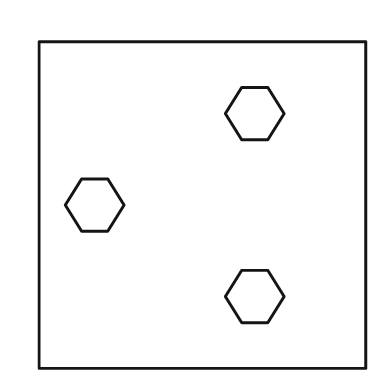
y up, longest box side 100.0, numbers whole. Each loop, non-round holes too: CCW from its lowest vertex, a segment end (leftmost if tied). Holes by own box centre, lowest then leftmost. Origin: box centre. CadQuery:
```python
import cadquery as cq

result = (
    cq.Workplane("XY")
    .moveTo(-50.0, -50.0)
    .lineTo(50.0, -50.0)
    .lineTo(50.0, 50.0)
    .lineTo(-50.0, 50.0)
    .close()
    .moveTo(12.0, -36.0)
    .lineTo(20.0, -36.0)
    .lineTo(25.0, -28.0)
    .lineTo(20.0, -20.0)
    .lineTo(12.0, -20.0)
    .lineTo(7.0, -28.0)
    .close()
    .moveTo(-37.0, -8.0)
    .lineTo(-29.0, -8.0)
    .lineTo(-24.0, 0.0)
    .lineTo(-29.0, 8.0)
    .lineTo(-37.0, 8.0)
    .lineTo(-42.0, 0.0)
    .close()
    .moveTo(12.0, 20.0)
    .lineTo(20.0, 20.0)
    .lineTo(25.0, 28.0)
    .lineTo(20.0, 36.0)
    .lineTo(12.0, 36.0)
    .lineTo(7.0, 28.0)
    .close()
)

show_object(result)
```